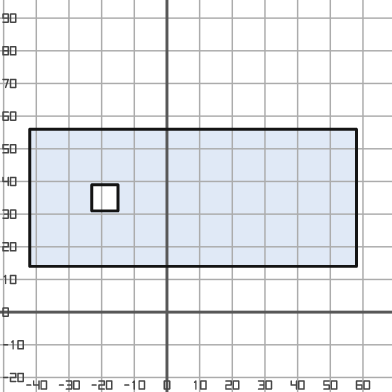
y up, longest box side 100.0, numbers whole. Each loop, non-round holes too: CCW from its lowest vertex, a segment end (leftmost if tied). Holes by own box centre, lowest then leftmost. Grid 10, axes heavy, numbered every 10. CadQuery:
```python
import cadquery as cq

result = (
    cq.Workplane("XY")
    .moveTo(-42.0, 14.0)
    .lineTo(58.0, 14.0)
    .lineTo(58.0, 56.0)
    .lineTo(-42.0, 56.0)
    .close()
    .moveTo(-23.0, 31.0)
    .lineTo(-15.0, 31.0)
    .lineTo(-15.0, 39.0)
    .lineTo(-23.0, 39.0)
    .close()
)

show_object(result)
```